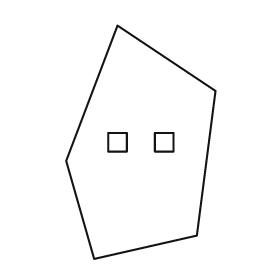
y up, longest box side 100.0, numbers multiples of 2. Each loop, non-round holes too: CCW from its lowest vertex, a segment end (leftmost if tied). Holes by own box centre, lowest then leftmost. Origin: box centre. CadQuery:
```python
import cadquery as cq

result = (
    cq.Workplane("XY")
    .moveTo(-20.0, -50.0)
    .lineTo(24.0, -40.0)
    .lineTo(32.0, 22.0)
    .lineTo(-10.0, 50.0)
    .lineTo(-32.0, -8.0)
    .close()
    .moveTo(-14.0, -4.0)
    .lineTo(-6.0, -4.0)
    .lineTo(-6.0, 4.0)
    .lineTo(-14.0, 4.0)
    .close()
    .moveTo(6.0, -4.0)
    .lineTo(14.0, -4.0)
    .lineTo(14.0, 4.0)
    .lineTo(6.0, 4.0)
    .close()
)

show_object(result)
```